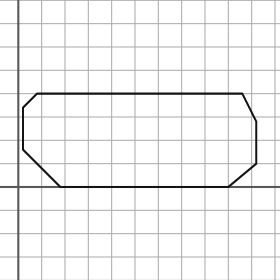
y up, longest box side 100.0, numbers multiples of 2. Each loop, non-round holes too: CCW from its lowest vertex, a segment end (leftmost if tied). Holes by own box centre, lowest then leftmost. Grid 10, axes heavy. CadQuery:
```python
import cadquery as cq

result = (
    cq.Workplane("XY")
    .moveTo(18.0, 0.0)
    .lineTo(90.0, 0.0)
    .lineTo(102.0, 10.0)
    .lineTo(102.0, 28.0)
    .lineTo(96.0, 40.0)
    .lineTo(8.0, 40.0)
    .lineTo(2.0, 34.0)
    .lineTo(2.0, 16.0)
    .close()
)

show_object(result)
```